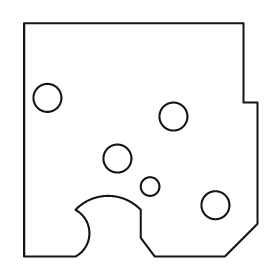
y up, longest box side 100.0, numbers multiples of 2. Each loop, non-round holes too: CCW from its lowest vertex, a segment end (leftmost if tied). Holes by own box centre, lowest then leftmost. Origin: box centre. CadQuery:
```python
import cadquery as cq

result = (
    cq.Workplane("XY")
    .moveTo(-50.0, -50.0)
    .lineTo(-28.0, -50.0)
    .threePointArc((-22.0, -40.0), (-28.0, -30.0))
    .threePointArc((-14.0, -24.0), (0.0, -30.0))
    .lineTo(0.0, -42.0)
    .lineTo(6.0, -50.0)
    .lineTo(36.0, -50.0)
    .lineTo(50.0, -36.0)
    .lineTo(50.0, 16.0)
    .lineTo(44.0, 16.0)
    .lineTo(44.0, 50.0)
    .lineTo(-50.0, 50.0)
    .close()
    .moveTo(32.0, -28.0)
    .circle(6.0)
    .moveTo(4.0, -20.0)
    .circle(4.0)
    .moveTo(-10.0, -8.0)
    .circle(6.0)
    .moveTo(14.0, 10.0)
    .circle(6.0)
    .moveTo(-40.0, 18.0)
    .circle(6.0)
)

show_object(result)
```